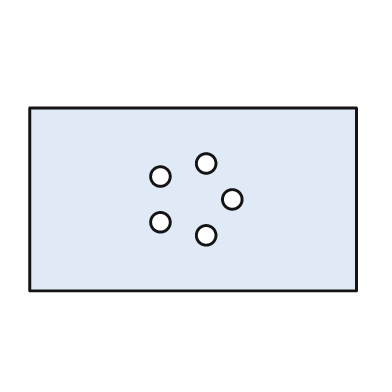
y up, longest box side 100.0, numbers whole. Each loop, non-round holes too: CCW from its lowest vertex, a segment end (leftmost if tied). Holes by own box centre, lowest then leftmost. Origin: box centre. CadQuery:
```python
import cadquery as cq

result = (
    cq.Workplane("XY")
    .moveTo(-50.0, -28.0)
    .lineTo(50.0, -28.0)
    .lineTo(50.0, 28.0)
    .lineTo(-50.0, 28.0)
    .close()
    .moveTo(4.0, -11.0)
    .circle(3.0)
    .moveTo(-10.0, -7.0)
    .circle(3.0)
    .moveTo(12.0, 0.0)
    .circle(3.0)
    .moveTo(-10.0, 7.0)
    .circle(3.0)
    .moveTo(4.0, 11.0)
    .circle(3.0)
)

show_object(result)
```